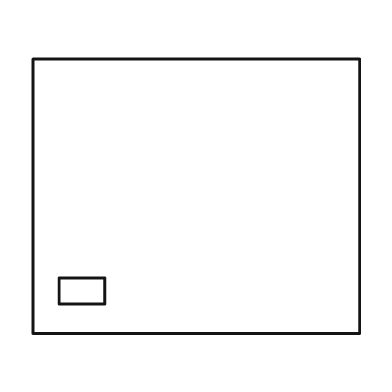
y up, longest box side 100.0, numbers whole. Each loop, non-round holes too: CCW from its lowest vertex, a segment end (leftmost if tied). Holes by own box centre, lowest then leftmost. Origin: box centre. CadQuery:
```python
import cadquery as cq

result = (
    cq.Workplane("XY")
    .moveTo(-50.0, -42.0)
    .lineTo(50.0, -42.0)
    .lineTo(50.0, 42.0)
    .lineTo(-50.0, 42.0)
    .close()
    .moveTo(-42.0, -33.0)
    .lineTo(-28.0, -33.0)
    .lineTo(-28.0, -25.0)
    .lineTo(-42.0, -25.0)
    .close()
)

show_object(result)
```